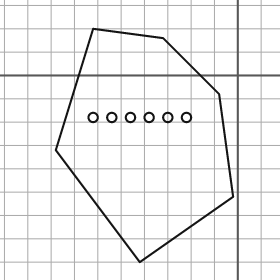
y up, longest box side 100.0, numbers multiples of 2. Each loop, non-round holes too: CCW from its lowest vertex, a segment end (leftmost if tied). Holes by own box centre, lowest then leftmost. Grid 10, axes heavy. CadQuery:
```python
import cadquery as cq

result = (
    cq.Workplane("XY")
    .moveTo(-42.0, -80.0)
    .lineTo(-2.0, -52.0)
    .lineTo(-8.0, -8.0)
    .lineTo(-32.0, 16.0)
    .lineTo(-62.0, 20.0)
    .lineTo(-78.0, -32.0)
    .close()
    .moveTo(-62.0, -18.0)
    .circle(2.0)
    .moveTo(-54.0, -18.0)
    .circle(2.0)
    .moveTo(-46.0, -18.0)
    .circle(2.0)
    .moveTo(-38.0, -18.0)
    .circle(2.0)
    .moveTo(-30.0, -18.0)
    .circle(2.0)
    .moveTo(-22.0, -18.0)
    .circle(2.0)
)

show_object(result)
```